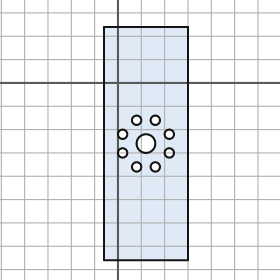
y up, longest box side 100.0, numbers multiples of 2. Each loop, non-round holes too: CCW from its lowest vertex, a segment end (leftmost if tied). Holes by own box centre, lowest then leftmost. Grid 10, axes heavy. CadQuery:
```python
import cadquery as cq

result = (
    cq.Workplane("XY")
    .moveTo(-6.0, -76.0)
    .lineTo(30.0, -76.0)
    .lineTo(30.0, 24.0)
    .lineTo(-6.0, 24.0)
    .close()
    .moveTo(8.0, -36.0)
    .circle(2.0)
    .moveTo(16.0, -36.0)
    .circle(2.0)
    .moveTo(2.0, -30.0)
    .circle(2.0)
    .moveTo(22.0, -30.0)
    .circle(2.0)
    .moveTo(12.0, -26.0)
    .circle(4.0)
    .moveTo(2.0, -22.0)
    .circle(2.0)
    .moveTo(22.0, -22.0)
    .circle(2.0)
    .moveTo(8.0, -16.0)
    .circle(2.0)
    .moveTo(16.0, -16.0)
    .circle(2.0)
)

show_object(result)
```